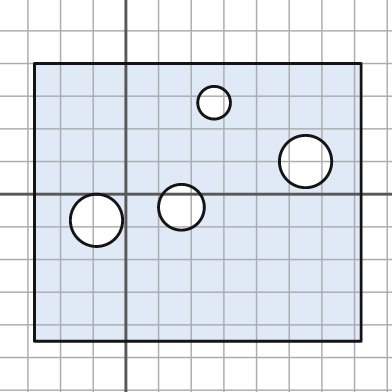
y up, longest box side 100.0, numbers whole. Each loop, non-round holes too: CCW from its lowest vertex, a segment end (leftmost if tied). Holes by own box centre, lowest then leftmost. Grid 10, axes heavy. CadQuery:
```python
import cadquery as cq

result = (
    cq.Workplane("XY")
    .moveTo(-28.0, -45.0)
    .lineTo(72.0, -45.0)
    .lineTo(72.0, 40.0)
    .lineTo(-28.0, 40.0)
    .close()
    .moveTo(-9.0, -8.0)
    .circle(8.0)
    .moveTo(17.0, -4.0)
    .circle(7.0)
    .moveTo(55.0, 10.0)
    .circle(8.0)
    .moveTo(27.0, 28.0)
    .circle(5.0)
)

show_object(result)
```